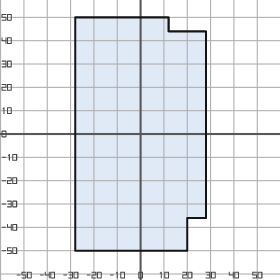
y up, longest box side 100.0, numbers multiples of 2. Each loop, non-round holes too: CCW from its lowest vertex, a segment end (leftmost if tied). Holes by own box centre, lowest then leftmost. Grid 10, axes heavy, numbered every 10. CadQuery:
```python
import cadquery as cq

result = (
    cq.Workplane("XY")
    .moveTo(-28.0, -50.0)
    .lineTo(20.0, -50.0)
    .lineTo(20.0, -36.0)
    .lineTo(28.0, -36.0)
    .lineTo(28.0, 44.0)
    .lineTo(12.0, 44.0)
    .lineTo(12.0, 50.0)
    .lineTo(-28.0, 50.0)
    .close()
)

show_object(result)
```